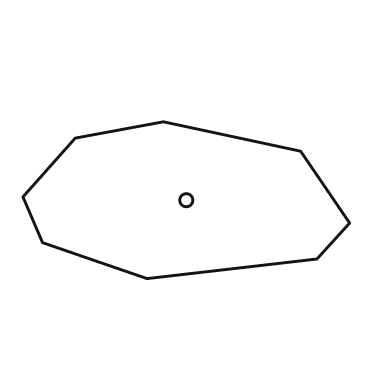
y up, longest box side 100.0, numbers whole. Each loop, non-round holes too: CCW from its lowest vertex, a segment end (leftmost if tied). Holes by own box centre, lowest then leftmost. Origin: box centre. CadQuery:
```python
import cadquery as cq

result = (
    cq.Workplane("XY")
    .moveTo(-12.0, -24.0)
    .lineTo(40.0, -18.0)
    .lineTo(50.0, -7.0)
    .lineTo(35.0, 15.0)
    .lineTo(-7.0, 24.0)
    .lineTo(-34.0, 19.0)
    .lineTo(-50.0, 1.0)
    .lineTo(-44.0, -13.0)
    .close()
    .moveTo(0.0, 0.0)
    .circle(2.0)
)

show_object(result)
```